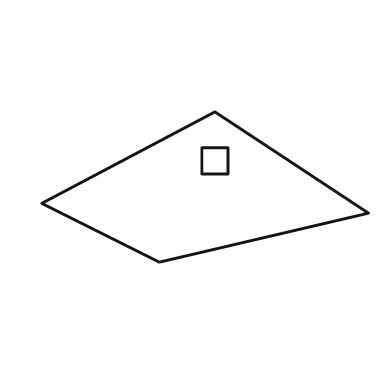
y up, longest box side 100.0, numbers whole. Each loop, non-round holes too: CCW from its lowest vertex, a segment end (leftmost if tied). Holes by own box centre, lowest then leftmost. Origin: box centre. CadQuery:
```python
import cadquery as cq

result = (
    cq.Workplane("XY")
    .moveTo(-14.0, -23.0)
    .lineTo(50.0, -8.0)
    .lineTo(3.0, 23.0)
    .lineTo(-50.0, -5.0)
    .close()
    .moveTo(-1.0, 4.0)
    .lineTo(7.0, 4.0)
    .lineTo(7.0, 12.0)
    .lineTo(-1.0, 12.0)
    .close()
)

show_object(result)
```